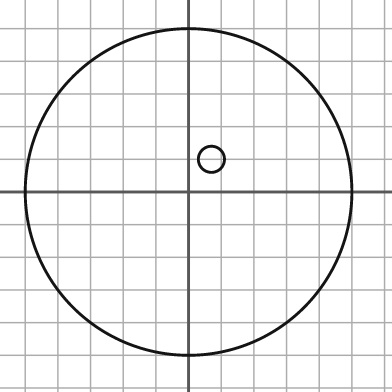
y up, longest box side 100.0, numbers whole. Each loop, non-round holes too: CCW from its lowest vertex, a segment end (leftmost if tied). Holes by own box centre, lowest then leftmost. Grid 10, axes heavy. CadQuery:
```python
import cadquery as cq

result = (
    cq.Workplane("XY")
    .moveTo(0.0, 0.0)
    .circle(50.0)
    .moveTo(7.0, 10.0)
    .circle(4.0)
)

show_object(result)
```